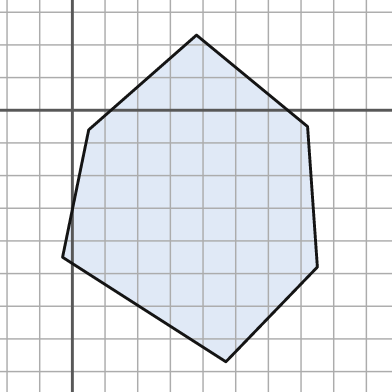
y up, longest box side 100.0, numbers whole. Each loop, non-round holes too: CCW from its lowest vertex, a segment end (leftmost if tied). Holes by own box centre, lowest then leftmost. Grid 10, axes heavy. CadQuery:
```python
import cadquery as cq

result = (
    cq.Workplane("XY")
    .moveTo(47.0, -77.0)
    .lineTo(75.0, -48.0)
    .lineTo(72.0, -5.0)
    .lineTo(38.0, 23.0)
    .lineTo(5.0, -6.0)
    .lineTo(-3.0, -45.0)
    .close()
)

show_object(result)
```